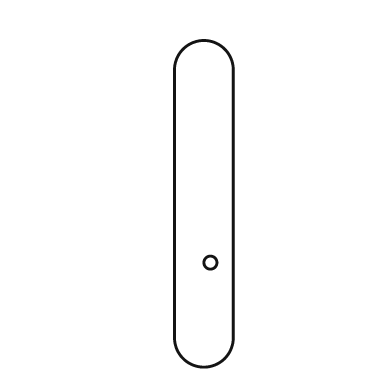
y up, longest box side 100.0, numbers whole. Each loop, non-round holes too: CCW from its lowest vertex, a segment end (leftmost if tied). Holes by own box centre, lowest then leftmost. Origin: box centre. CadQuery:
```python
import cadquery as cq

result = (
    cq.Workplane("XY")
    .moveTo(-9.0, -41.0)
    .threePointArc((0.0, -50.0), (9.0, -41.0))
    .lineTo(9.0, 41.0)
    .threePointArc((0.0, 50.0), (-9.0, 41.0))
    .close()
    .moveTo(2.0, -18.0)
    .circle(2.0)
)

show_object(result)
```